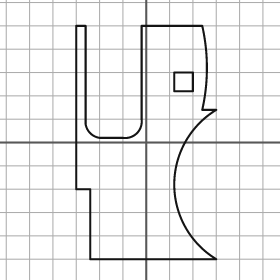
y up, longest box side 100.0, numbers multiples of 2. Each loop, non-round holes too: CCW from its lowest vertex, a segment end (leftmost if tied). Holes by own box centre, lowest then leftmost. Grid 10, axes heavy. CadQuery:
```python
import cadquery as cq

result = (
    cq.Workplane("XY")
    .moveTo(-24.0, -50.0)
    .lineTo(30.0, -50.0)
    .threePointArc((12.0, -18.0), (30.0, 14.0))
    .lineTo(24.0, 14.0)
    .threePointArc((26.0, 32.0), (24.0, 50.0))
    .lineTo(-2.0, 50.0)
    .lineTo(-2.0, 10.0)
    .threePointArc((-4.0, 4.0), (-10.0, 2.0))
    .lineTo(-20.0, 2.0)
    .threePointArc((-24.0, 4.0), (-26.0, 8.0))
    .lineTo(-26.0, 50.0)
    .lineTo(-30.0, 50.0)
    .lineTo(-30.0, -20.0)
    .lineTo(-24.0, -20.0)
    .close()
    .moveTo(12.0, 22.0)
    .lineTo(20.0, 22.0)
    .lineTo(20.0, 30.0)
    .lineTo(12.0, 30.0)
    .close()
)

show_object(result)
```